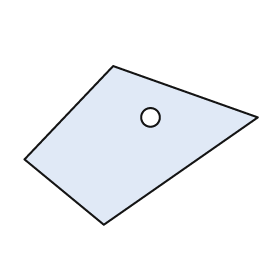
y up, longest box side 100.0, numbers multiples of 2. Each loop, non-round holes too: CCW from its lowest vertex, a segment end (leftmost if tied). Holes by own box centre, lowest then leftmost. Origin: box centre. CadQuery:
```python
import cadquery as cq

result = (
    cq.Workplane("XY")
    .moveTo(-16.0, -34.0)
    .lineTo(50.0, 12.0)
    .lineTo(-12.0, 34.0)
    .lineTo(-50.0, -6.0)
    .close()
    .moveTo(4.0, 12.0)
    .circle(4.0)
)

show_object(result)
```